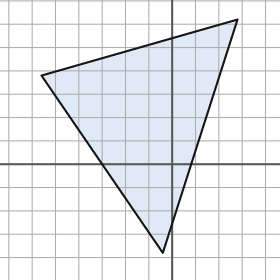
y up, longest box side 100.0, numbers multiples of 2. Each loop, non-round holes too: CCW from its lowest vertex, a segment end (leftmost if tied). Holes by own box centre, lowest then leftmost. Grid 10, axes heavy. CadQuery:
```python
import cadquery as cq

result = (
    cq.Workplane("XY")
    .moveTo(-4.0, -38.0)
    .lineTo(28.0, 62.0)
    .lineTo(-56.0, 38.0)
    .close()
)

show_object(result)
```